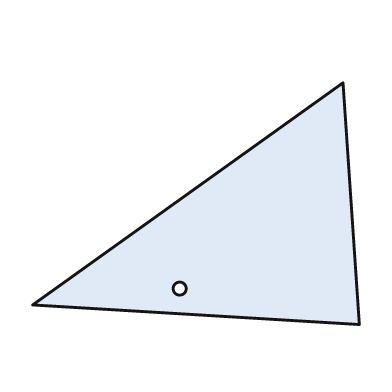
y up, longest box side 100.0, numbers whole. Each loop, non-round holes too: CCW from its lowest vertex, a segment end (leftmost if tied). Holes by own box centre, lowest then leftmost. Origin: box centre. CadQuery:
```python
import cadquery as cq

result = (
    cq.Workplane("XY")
    .moveTo(50.0, -37.0)
    .lineTo(45.0, 37.0)
    .lineTo(-50.0, -31.0)
    .close()
    .moveTo(-5.0, -26.0)
    .circle(2.0)
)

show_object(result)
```